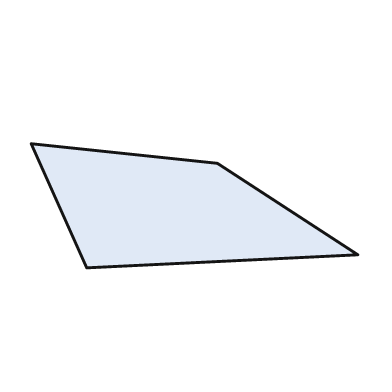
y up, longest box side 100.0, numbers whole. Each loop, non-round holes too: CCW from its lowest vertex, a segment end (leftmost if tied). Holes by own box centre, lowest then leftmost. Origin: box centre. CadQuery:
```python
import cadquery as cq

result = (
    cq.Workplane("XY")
    .moveTo(-33.0, -19.0)
    .lineTo(50.0, -15.0)
    .lineTo(7.0, 13.0)
    .lineTo(-50.0, 19.0)
    .close()
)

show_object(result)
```